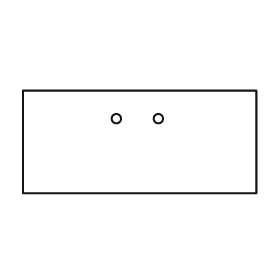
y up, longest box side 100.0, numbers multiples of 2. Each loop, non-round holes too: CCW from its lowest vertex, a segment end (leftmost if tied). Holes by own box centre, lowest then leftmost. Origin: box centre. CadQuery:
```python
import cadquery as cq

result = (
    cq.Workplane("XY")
    .moveTo(-50.0, -22.0)
    .lineTo(50.0, -22.0)
    .lineTo(50.0, 22.0)
    .lineTo(-50.0, 22.0)
    .close()
    .moveTo(-10.0, 10.0)
    .circle(2.0)
    .moveTo(8.0, 10.0)
    .circle(2.0)
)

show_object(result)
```